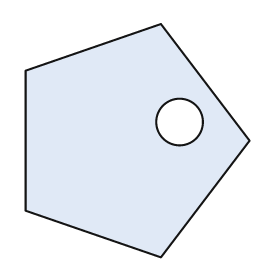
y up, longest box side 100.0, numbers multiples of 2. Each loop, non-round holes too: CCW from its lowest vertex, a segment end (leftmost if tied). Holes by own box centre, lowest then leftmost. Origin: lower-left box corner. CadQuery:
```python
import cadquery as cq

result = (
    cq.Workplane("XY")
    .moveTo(58.0, 0.0)
    .lineTo(96.0, 50.0)
    .lineTo(58.0, 100.0)
    .lineTo(0.0, 80.0)
    .lineTo(0.0, 20.0)
    .close()
    .moveTo(66.0, 58.0)
    .circle(10.0)
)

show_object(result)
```